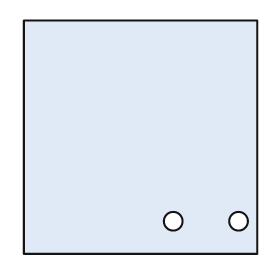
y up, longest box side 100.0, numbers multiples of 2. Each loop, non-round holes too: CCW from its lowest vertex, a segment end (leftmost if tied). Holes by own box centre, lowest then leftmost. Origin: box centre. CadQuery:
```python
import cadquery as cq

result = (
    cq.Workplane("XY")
    .moveTo(-50.0, -50.0)
    .lineTo(50.0, -50.0)
    .lineTo(50.0, 50.0)
    .lineTo(-50.0, 50.0)
    .close()
    .moveTo(14.0, -36.0)
    .circle(4.0)
    .moveTo(42.0, -36.0)
    .circle(4.0)
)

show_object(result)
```